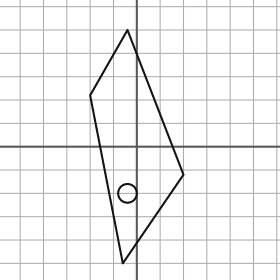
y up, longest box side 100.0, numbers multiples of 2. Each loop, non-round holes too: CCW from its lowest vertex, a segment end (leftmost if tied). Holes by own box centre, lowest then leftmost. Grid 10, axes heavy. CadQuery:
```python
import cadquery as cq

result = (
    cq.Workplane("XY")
    .moveTo(-6.0, -50.0)
    .lineTo(20.0, -12.0)
    .lineTo(-4.0, 50.0)
    .lineTo(-20.0, 22.0)
    .close()
    .moveTo(-4.0, -20.0)
    .circle(4.0)
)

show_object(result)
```